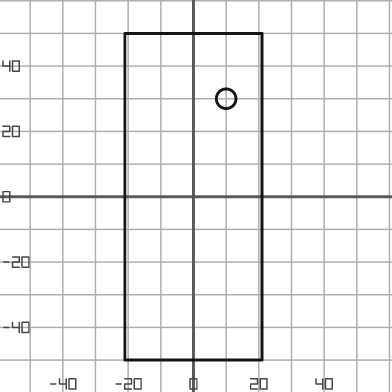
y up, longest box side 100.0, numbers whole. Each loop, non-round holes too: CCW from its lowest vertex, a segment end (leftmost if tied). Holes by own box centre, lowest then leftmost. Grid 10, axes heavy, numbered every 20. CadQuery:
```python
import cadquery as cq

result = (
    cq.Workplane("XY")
    .moveTo(-21.0, -50.0)
    .lineTo(21.0, -50.0)
    .lineTo(21.0, 50.0)
    .lineTo(-21.0, 50.0)
    .close()
    .moveTo(10.0, 30.0)
    .circle(3.0)
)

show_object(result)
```